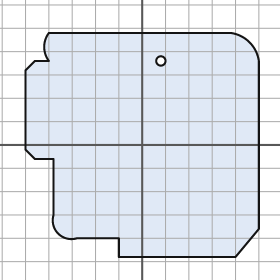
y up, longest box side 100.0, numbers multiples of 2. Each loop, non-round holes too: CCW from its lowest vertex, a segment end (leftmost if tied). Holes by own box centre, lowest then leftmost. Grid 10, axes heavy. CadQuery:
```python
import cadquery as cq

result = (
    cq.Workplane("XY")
    .moveTo(-10.0, -48.0)
    .lineTo(40.0, -48.0)
    .lineTo(50.0, -36.0)
    .lineTo(50.0, 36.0)
    .threePointArc((46.0, 44.0), (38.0, 48.0))
    .lineTo(-40.0, 48.0)
    .threePointArc((-42.0, 42.0), (-40.0, 36.0))
    .lineTo(-46.0, 36.0)
    .lineTo(-50.0, 32.0)
    .lineTo(-50.0, -2.0)
    .lineTo(-46.0, -6.0)
    .lineTo(-38.0, -6.0)
    .lineTo(-38.0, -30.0)
    .threePointArc((-36.0, -38.0), (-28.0, -40.0))
    .lineTo(-10.0, -40.0)
    .close()
    .moveTo(8.0, 36.0)
    .circle(2.0)
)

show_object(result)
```